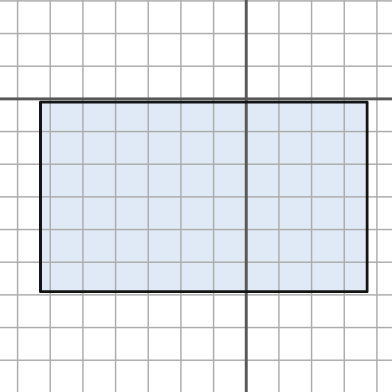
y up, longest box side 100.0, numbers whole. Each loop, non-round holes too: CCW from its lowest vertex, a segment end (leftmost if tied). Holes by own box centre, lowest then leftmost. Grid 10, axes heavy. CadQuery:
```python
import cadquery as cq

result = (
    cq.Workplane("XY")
    .moveTo(-63.0, -59.0)
    .lineTo(37.0, -59.0)
    .lineTo(37.0, -1.0)
    .lineTo(-63.0, -1.0)
    .close()
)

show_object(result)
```